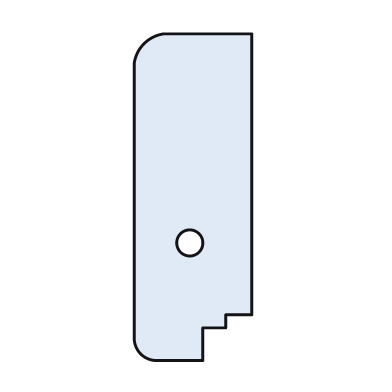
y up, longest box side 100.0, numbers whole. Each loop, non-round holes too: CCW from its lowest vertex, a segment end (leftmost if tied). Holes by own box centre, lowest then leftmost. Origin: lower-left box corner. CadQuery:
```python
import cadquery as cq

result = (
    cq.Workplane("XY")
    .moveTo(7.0, 0.0)
    .lineTo(21.0, 0.0)
    .lineTo(21.0, 10.0)
    .lineTo(28.0, 10.0)
    .lineTo(28.0, 14.0)
    .lineTo(36.0, 14.0)
    .lineTo(36.0, 100.0)
    .lineTo(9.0, 100.0)
    .threePointArc((3.0, 97.0), (0.0, 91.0))
    .lineTo(0.0, 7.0)
    .threePointArc((2.0, 2.0), (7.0, 0.0))
    .close()
    .moveTo(17.0, 36.0)
    .circle(4.0)
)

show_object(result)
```